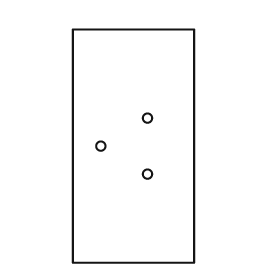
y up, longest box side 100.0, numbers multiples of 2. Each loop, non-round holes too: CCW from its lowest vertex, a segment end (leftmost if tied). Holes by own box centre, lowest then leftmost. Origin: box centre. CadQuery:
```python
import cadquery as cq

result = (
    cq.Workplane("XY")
    .moveTo(-26.0, -50.0)
    .lineTo(26.0, -50.0)
    .lineTo(26.0, 50.0)
    .lineTo(-26.0, 50.0)
    .close()
    .moveTo(6.0, -12.0)
    .circle(2.0)
    .moveTo(-14.0, 0.0)
    .circle(2.0)
    .moveTo(6.0, 12.0)
    .circle(2.0)
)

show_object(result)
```